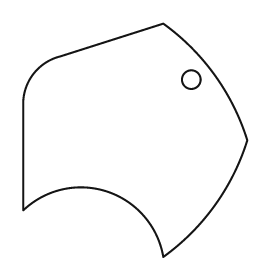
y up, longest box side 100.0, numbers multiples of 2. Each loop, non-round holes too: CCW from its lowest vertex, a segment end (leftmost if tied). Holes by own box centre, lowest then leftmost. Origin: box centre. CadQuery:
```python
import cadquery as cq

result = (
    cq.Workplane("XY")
    .moveTo(12.0, -50.0)
    .threePointArc((34.0, -28.0), (48.0, 0.0))
    .threePointArc((34.0, 28.0), (12.0, 50.0))
    .lineTo(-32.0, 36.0)
    .threePointArc((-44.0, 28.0), (-48.0, 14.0))
    .lineTo(-48.0, -30.0)
    .threePointArc((-12.0, -22.0), (12.0, -50.0))
    .close()
    .moveTo(24.0, 26.0)
    .circle(4.0)
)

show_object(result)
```